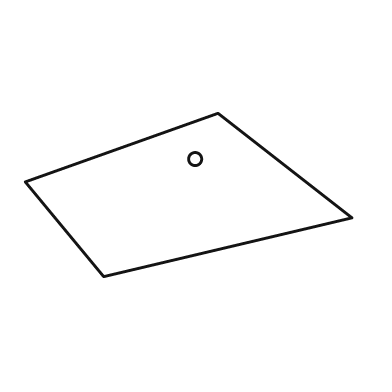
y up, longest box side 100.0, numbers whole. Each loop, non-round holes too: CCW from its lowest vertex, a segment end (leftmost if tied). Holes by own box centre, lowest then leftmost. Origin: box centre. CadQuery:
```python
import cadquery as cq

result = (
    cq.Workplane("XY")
    .moveTo(-26.0, -25.0)
    .lineTo(50.0, -7.0)
    .lineTo(9.0, 25.0)
    .lineTo(-50.0, 4.0)
    .close()
    .moveTo(2.0, 11.0)
    .circle(2.0)
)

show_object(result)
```